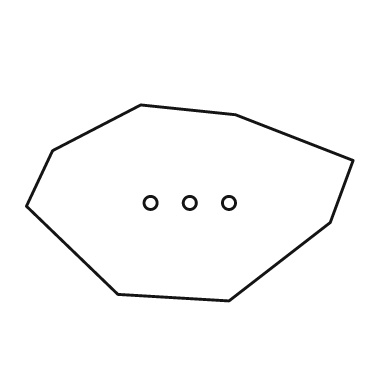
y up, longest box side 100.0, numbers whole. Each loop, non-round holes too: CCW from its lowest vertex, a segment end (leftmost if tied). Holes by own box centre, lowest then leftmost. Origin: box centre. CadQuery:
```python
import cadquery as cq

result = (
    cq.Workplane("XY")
    .moveTo(12.0, -30.0)
    .lineTo(43.0, -6.0)
    .lineTo(50.0, 13.0)
    .lineTo(14.0, 27.0)
    .lineTo(-15.0, 30.0)
    .lineTo(-42.0, 16.0)
    .lineTo(-50.0, -1.0)
    .lineTo(-22.0, -28.0)
    .close()
    .moveTo(-12.0, 0.0)
    .circle(2.0)
    .moveTo(0.0, 0.0)
    .circle(2.0)
    .moveTo(12.0, 0.0)
    .circle(2.0)
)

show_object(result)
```